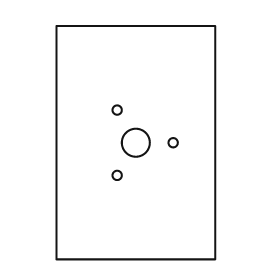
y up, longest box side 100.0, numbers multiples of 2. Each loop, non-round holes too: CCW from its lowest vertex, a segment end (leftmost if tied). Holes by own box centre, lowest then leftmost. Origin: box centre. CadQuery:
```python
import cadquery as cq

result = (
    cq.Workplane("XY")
    .moveTo(-34.0, -50.0)
    .lineTo(34.0, -50.0)
    .lineTo(34.0, 50.0)
    .lineTo(-34.0, 50.0)
    .close()
    .moveTo(-8.0, -14.0)
    .circle(2.0)
    .moveTo(0.0, 0.0)
    .circle(6.0)
    .moveTo(16.0, 0.0)
    .circle(2.0)
    .moveTo(-8.0, 14.0)
    .circle(2.0)
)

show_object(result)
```